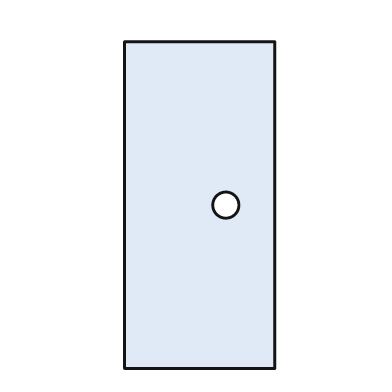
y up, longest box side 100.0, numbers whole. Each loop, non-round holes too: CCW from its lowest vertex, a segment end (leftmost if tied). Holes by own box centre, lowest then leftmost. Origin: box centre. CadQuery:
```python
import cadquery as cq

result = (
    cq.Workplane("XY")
    .moveTo(-23.0, -50.0)
    .lineTo(23.0, -50.0)
    .lineTo(23.0, 50.0)
    .lineTo(-23.0, 50.0)
    .close()
    .moveTo(8.0, 0.0)
    .circle(4.0)
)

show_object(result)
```